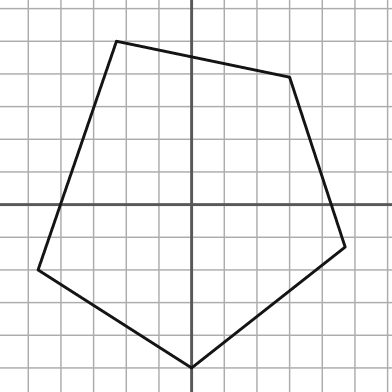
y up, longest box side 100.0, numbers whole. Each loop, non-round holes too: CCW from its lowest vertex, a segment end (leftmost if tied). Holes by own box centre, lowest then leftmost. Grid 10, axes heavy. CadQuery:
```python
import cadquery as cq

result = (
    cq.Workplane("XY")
    .moveTo(0.0, -50.0)
    .lineTo(47.0, -13.0)
    .lineTo(30.0, 39.0)
    .lineTo(-23.0, 50.0)
    .lineTo(-47.0, -20.0)
    .close()
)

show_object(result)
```